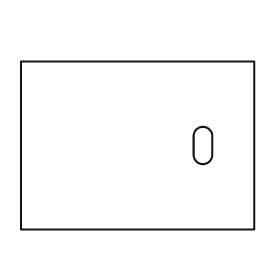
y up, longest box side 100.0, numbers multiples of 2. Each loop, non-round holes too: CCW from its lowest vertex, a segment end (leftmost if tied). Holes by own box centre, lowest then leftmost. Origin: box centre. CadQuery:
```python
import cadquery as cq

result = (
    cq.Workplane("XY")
    .moveTo(-50.0, -36.0)
    .lineTo(50.0, -36.0)
    .lineTo(50.0, 36.0)
    .lineTo(-50.0, 36.0)
    .close()
    .moveTo(24.0, -4.0)
    .threePointArc((28.0, -8.0), (32.0, -4.0))
    .lineTo(32.0, 4.0)
    .threePointArc((28.0, 8.0), (24.0, 4.0))
    .close()
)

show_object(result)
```